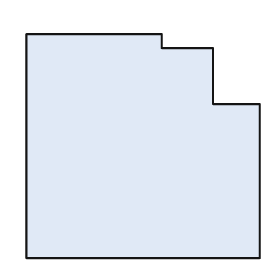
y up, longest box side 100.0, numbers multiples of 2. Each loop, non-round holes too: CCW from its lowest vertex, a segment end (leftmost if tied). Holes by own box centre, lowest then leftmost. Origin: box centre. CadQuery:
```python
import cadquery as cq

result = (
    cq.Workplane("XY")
    .moveTo(-50.0, -48.0)
    .lineTo(50.0, -48.0)
    .lineTo(50.0, 18.0)
    .lineTo(30.0, 18.0)
    .lineTo(30.0, 42.0)
    .lineTo(8.0, 42.0)
    .lineTo(8.0, 48.0)
    .lineTo(-50.0, 48.0)
    .close()
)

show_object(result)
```